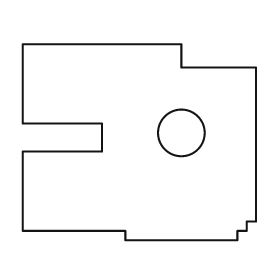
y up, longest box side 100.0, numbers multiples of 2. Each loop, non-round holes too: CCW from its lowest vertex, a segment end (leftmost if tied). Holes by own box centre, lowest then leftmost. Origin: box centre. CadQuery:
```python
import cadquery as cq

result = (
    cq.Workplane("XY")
    .moveTo(-6.0, -42.0)
    .lineTo(42.0, -42.0)
    .lineTo(42.0, -38.0)
    .lineTo(46.0, -38.0)
    .lineTo(46.0, -34.0)
    .lineTo(50.0, -34.0)
    .lineTo(50.0, 32.0)
    .lineTo(18.0, 32.0)
    .lineTo(18.0, 42.0)
    .lineTo(-50.0, 42.0)
    .lineTo(-50.0, 8.0)
    .lineTo(-16.0, 8.0)
    .lineTo(-16.0, -4.0)
    .lineTo(-50.0, -4.0)
    .lineTo(-50.0, -38.0)
    .lineTo(-6.0, -38.0)
    .close()
    .moveTo(18.0, 4.0)
    .circle(10.0)
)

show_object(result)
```